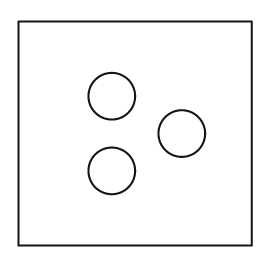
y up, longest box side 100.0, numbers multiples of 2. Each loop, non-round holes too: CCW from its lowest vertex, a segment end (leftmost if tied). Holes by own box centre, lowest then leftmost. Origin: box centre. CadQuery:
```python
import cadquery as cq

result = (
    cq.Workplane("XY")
    .moveTo(-50.0, -48.0)
    .lineTo(50.0, -48.0)
    .lineTo(50.0, 48.0)
    .lineTo(-50.0, 48.0)
    .close()
    .moveTo(-10.0, -16.0)
    .circle(10.0)
    .moveTo(20.0, 0.0)
    .circle(10.0)
    .moveTo(-10.0, 16.0)
    .circle(10.0)
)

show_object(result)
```